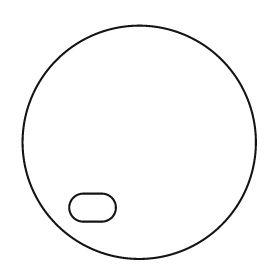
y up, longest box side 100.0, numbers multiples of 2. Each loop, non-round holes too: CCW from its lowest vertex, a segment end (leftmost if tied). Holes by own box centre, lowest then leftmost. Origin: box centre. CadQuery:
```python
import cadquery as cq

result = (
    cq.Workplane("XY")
    .moveTo(0.0, 0.0)
    .circle(50.0)
    .moveTo(-24.0, -34.0)
    .lineTo(-16.0, -34.0)
    .threePointArc((-10.0, -28.0), (-16.0, -22.0))
    .lineTo(-24.0, -22.0)
    .threePointArc((-30.0, -28.0), (-24.0, -34.0))
    .close()
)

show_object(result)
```